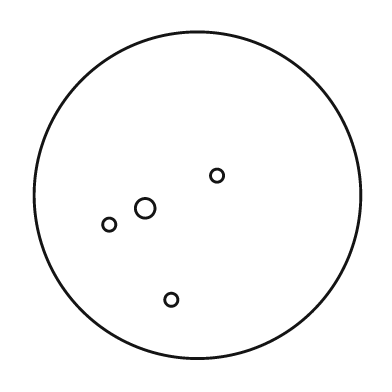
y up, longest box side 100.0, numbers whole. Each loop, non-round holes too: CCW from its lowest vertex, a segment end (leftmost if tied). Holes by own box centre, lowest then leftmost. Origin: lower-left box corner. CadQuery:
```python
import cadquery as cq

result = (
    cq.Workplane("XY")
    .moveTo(50.0, 50.0)
    .circle(50.0)
    .moveTo(42.0, 18.0)
    .circle(2.0)
    .moveTo(23.0, 41.0)
    .circle(2.0)
    .moveTo(34.0, 46.0)
    .circle(3.0)
    .moveTo(56.0, 56.0)
    .circle(2.0)
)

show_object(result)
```